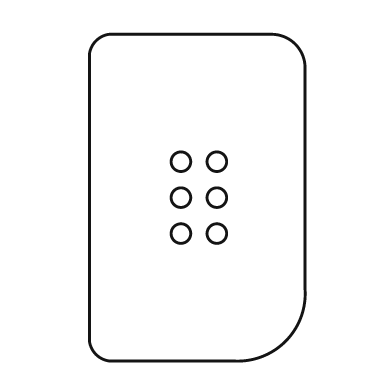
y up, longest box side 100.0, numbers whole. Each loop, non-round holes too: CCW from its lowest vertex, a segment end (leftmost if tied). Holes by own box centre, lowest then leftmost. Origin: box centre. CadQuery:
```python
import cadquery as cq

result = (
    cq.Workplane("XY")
    .moveTo(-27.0, -50.0)
    .lineTo(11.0, -50.0)
    .threePointArc((27.0, -44.0), (33.0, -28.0))
    .lineTo(33.0, 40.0)
    .threePointArc((30.0, 47.0), (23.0, 50.0))
    .lineTo(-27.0, 50.0)
    .threePointArc((-31.0, 48.0), (-33.0, 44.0))
    .lineTo(-33.0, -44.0)
    .threePointArc((-31.0, -48.0), (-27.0, -50.0))
    .close()
    .moveTo(-5.0, -11.0)
    .circle(3.0)
    .moveTo(6.0, -11.0)
    .circle(3.0)
    .moveTo(-5.0, 0.0)
    .circle(3.0)
    .moveTo(6.0, 0.0)
    .circle(3.0)
    .moveTo(-5.0, 11.0)
    .circle(3.0)
    .moveTo(6.0, 11.0)
    .circle(3.0)
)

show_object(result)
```